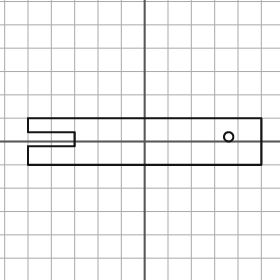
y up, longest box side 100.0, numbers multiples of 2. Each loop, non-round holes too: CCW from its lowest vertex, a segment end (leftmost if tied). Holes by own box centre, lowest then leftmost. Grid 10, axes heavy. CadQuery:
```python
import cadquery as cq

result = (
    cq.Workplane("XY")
    .moveTo(-50.0, -10.0)
    .lineTo(50.0, -10.0)
    .lineTo(50.0, 10.0)
    .lineTo(-50.0, 10.0)
    .lineTo(-50.0, 4.0)
    .lineTo(-30.0, 4.0)
    .lineTo(-30.0, -2.0)
    .lineTo(-50.0, -2.0)
    .close()
    .moveTo(36.0, 2.0)
    .circle(2.0)
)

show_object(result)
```